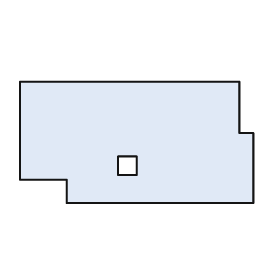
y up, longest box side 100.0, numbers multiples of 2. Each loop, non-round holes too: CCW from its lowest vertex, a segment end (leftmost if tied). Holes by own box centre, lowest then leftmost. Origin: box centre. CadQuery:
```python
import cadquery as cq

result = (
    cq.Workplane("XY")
    .moveTo(-30.0, -26.0)
    .lineTo(50.0, -26.0)
    .lineTo(50.0, 4.0)
    .lineTo(44.0, 4.0)
    .lineTo(44.0, 26.0)
    .lineTo(-50.0, 26.0)
    .lineTo(-50.0, -16.0)
    .lineTo(-30.0, -16.0)
    .close()
    .moveTo(-8.0, -14.0)
    .lineTo(0.0, -14.0)
    .lineTo(0.0, -6.0)
    .lineTo(-8.0, -6.0)
    .close()
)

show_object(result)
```